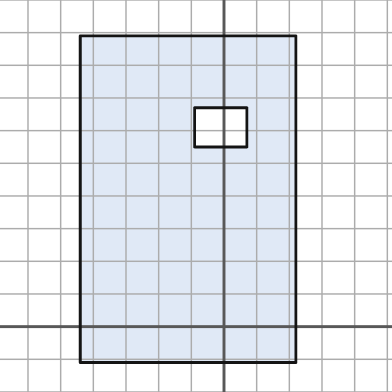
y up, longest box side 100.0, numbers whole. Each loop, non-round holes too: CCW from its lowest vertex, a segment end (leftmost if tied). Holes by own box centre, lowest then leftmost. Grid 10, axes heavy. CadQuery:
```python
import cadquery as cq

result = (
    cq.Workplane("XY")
    .moveTo(-44.0, -11.0)
    .lineTo(22.0, -11.0)
    .lineTo(22.0, 89.0)
    .lineTo(-44.0, 89.0)
    .close()
    .moveTo(-9.0, 55.0)
    .lineTo(7.0, 55.0)
    .lineTo(7.0, 67.0)
    .lineTo(-9.0, 67.0)
    .close()
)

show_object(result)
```